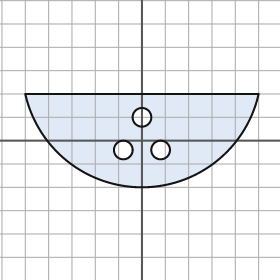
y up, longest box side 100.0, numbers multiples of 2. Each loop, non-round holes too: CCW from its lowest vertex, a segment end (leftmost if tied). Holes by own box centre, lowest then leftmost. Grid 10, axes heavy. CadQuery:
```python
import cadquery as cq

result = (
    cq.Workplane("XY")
    .moveTo(-50.0, 20.0)
    .threePointArc((0.0, -20.0), (50.0, 20.0))
    .close()
    .moveTo(-8.0, -4.0)
    .circle(4.0)
    .moveTo(8.0, -4.0)
    .circle(4.0)
    .moveTo(0.0, 10.0)
    .circle(4.0)
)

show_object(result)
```